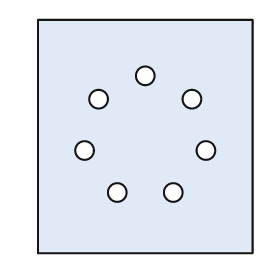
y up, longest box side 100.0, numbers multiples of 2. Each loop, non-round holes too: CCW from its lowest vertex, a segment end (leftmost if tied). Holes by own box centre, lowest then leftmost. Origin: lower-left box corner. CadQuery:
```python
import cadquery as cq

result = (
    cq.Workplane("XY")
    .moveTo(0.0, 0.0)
    .lineTo(92.0, 0.0)
    .lineTo(92.0, 100.0)
    .lineTo(0.0, 100.0)
    .close()
    .moveTo(34.0, 26.0)
    .circle(4.0)
    .moveTo(58.0, 26.0)
    .circle(4.0)
    .moveTo(20.0, 44.0)
    .circle(4.0)
    .moveTo(72.0, 44.0)
    .circle(4.0)
    .moveTo(26.0, 66.0)
    .circle(4.0)
    .moveTo(66.0, 66.0)
    .circle(4.0)
    .moveTo(46.0, 76.0)
    .circle(4.0)
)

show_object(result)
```